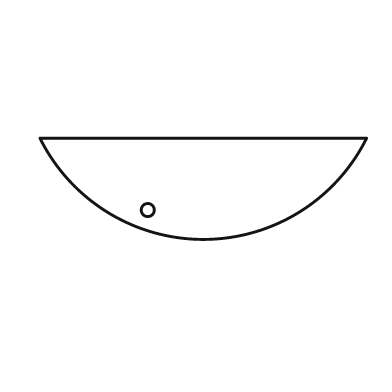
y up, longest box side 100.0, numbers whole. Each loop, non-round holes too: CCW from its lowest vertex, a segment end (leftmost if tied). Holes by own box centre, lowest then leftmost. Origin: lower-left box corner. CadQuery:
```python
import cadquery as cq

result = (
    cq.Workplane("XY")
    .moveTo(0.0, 31.0)
    .threePointArc((50.0, 0.0), (100.0, 31.0))
    .close()
    .moveTo(33.0, 9.0)
    .circle(2.0)
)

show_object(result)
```